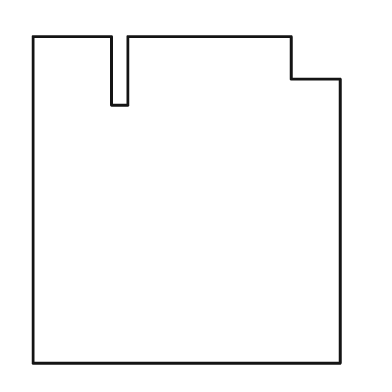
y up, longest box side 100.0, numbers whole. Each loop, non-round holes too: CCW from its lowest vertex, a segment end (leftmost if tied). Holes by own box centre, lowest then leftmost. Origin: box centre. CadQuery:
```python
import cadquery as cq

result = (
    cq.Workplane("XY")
    .moveTo(-47.0, -50.0)
    .lineTo(47.0, -50.0)
    .lineTo(47.0, 37.0)
    .lineTo(32.0, 37.0)
    .lineTo(32.0, 50.0)
    .lineTo(-18.0, 50.0)
    .lineTo(-18.0, 29.0)
    .lineTo(-23.0, 29.0)
    .lineTo(-23.0, 50.0)
    .lineTo(-47.0, 50.0)
    .close()
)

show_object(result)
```